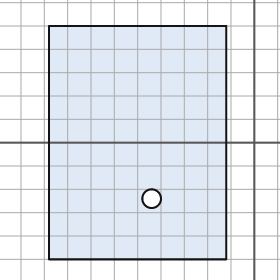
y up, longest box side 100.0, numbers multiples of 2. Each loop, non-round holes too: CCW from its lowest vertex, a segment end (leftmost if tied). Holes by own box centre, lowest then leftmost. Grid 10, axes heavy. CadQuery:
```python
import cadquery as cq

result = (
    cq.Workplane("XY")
    .moveTo(-88.0, -50.0)
    .lineTo(-12.0, -50.0)
    .lineTo(-12.0, 50.0)
    .lineTo(-88.0, 50.0)
    .close()
    .moveTo(-44.0, -24.0)
    .circle(4.0)
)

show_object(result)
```